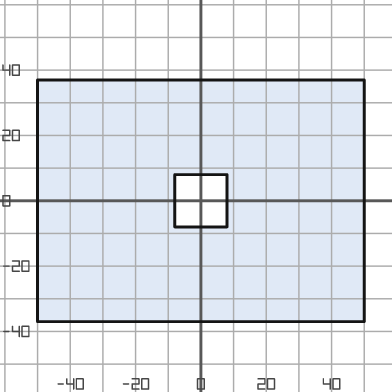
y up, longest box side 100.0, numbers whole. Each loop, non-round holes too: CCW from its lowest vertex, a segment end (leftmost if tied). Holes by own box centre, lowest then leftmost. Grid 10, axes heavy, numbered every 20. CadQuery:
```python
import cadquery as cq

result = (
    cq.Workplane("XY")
    .moveTo(-50.0, -37.0)
    .lineTo(50.0, -37.0)
    .lineTo(50.0, 37.0)
    .lineTo(-50.0, 37.0)
    .close()
    .moveTo(-8.0, -8.0)
    .lineTo(8.0, -8.0)
    .lineTo(8.0, 8.0)
    .lineTo(-8.0, 8.0)
    .close()
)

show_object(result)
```